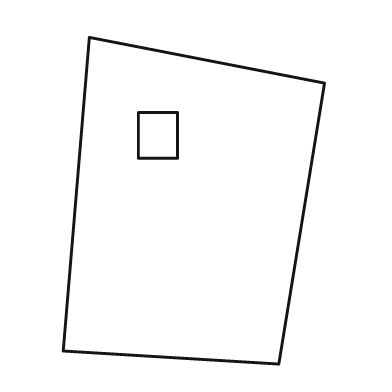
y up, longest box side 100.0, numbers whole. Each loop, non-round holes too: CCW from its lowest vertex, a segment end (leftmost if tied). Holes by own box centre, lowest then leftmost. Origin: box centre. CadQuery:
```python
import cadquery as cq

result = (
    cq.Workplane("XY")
    .moveTo(26.0, -50.0)
    .lineTo(40.0, 36.0)
    .lineTo(-32.0, 50.0)
    .lineTo(-40.0, -46.0)
    .close()
    .moveTo(-17.0, 13.0)
    .lineTo(-5.0, 13.0)
    .lineTo(-5.0, 27.0)
    .lineTo(-17.0, 27.0)
    .close()
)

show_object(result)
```